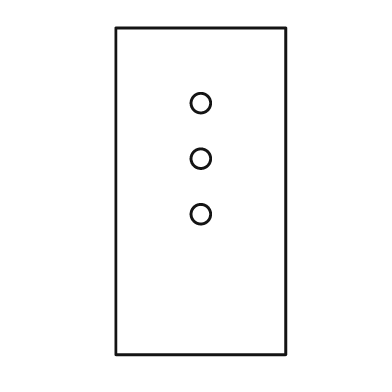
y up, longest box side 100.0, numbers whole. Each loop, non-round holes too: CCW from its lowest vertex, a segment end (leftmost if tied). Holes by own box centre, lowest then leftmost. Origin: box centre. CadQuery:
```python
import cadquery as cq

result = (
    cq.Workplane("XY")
    .moveTo(-26.0, -50.0)
    .lineTo(26.0, -50.0)
    .lineTo(26.0, 50.0)
    .lineTo(-26.0, 50.0)
    .close()
    .moveTo(0.0, -7.0)
    .circle(3.0)
    .moveTo(0.0, 10.0)
    .circle(3.0)
    .moveTo(0.0, 27.0)
    .circle(3.0)
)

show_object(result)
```